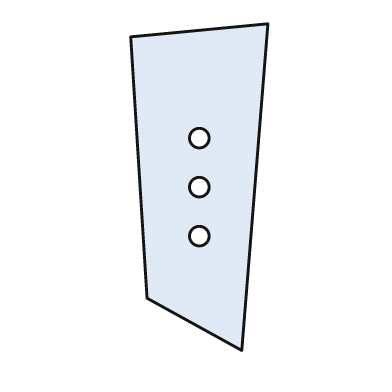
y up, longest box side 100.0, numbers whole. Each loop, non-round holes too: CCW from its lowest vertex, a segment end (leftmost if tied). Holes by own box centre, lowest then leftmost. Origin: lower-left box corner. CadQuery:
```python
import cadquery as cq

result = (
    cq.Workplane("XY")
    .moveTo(34.0, 0.0)
    .lineTo(42.0, 100.0)
    .lineTo(0.0, 96.0)
    .lineTo(5.0, 16.0)
    .close()
    .moveTo(21.0, 35.0)
    .circle(3.0)
    .moveTo(21.0, 50.0)
    .circle(3.0)
    .moveTo(21.0, 65.0)
    .circle(3.0)
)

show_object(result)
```